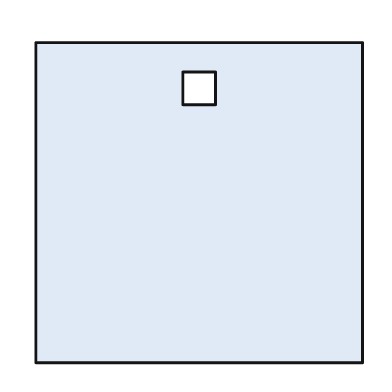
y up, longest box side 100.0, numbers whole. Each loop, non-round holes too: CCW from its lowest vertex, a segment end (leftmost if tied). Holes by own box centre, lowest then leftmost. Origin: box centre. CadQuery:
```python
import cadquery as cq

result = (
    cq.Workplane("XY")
    .moveTo(-50.0, -49.0)
    .lineTo(50.0, -49.0)
    .lineTo(50.0, 49.0)
    .lineTo(-50.0, 49.0)
    .close()
    .moveTo(-5.0, 30.0)
    .lineTo(5.0, 30.0)
    .lineTo(5.0, 40.0)
    .lineTo(-5.0, 40.0)
    .close()
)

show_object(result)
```